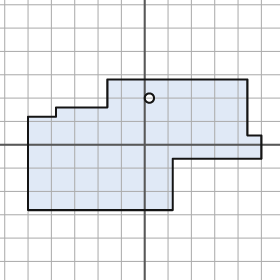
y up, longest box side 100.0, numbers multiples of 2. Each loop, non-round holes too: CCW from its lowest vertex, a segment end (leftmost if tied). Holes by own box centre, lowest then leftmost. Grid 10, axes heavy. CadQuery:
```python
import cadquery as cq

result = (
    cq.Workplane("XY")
    .moveTo(-50.0, -28.0)
    .lineTo(12.0, -28.0)
    .lineTo(12.0, -6.0)
    .lineTo(50.0, -6.0)
    .lineTo(50.0, 4.0)
    .lineTo(44.0, 4.0)
    .lineTo(44.0, 28.0)
    .lineTo(-16.0, 28.0)
    .lineTo(-16.0, 16.0)
    .lineTo(-38.0, 16.0)
    .lineTo(-38.0, 12.0)
    .lineTo(-50.0, 12.0)
    .close()
    .moveTo(2.0, 20.0)
    .circle(2.0)
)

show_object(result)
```